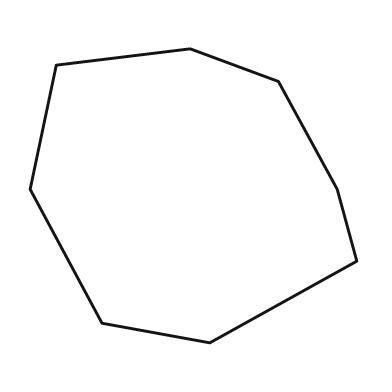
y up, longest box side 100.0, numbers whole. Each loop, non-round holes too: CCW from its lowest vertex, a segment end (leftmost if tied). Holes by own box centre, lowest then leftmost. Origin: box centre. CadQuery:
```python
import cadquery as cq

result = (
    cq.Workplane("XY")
    .moveTo(5.0, -45.0)
    .lineTo(50.0, -20.0)
    .lineTo(44.0, 2.0)
    .lineTo(26.0, 35.0)
    .lineTo(-1.0, 45.0)
    .lineTo(-42.0, 40.0)
    .lineTo(-50.0, 2.0)
    .lineTo(-28.0, -39.0)
    .close()
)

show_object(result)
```